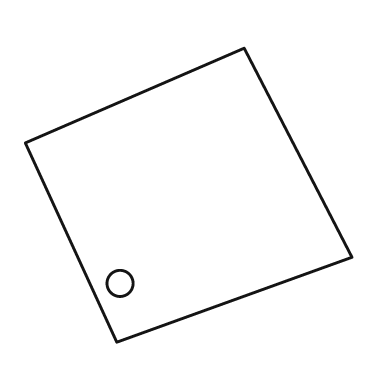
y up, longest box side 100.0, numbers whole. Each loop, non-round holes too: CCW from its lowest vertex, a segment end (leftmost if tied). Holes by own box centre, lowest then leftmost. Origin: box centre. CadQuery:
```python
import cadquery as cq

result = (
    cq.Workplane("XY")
    .moveTo(-22.0, -45.0)
    .lineTo(50.0, -19.0)
    .lineTo(17.0, 45.0)
    .lineTo(-50.0, 16.0)
    .close()
    .moveTo(-21.0, -27.0)
    .circle(4.0)
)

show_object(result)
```